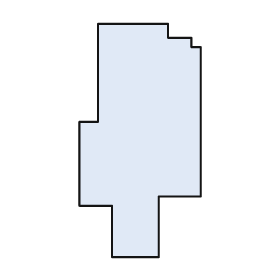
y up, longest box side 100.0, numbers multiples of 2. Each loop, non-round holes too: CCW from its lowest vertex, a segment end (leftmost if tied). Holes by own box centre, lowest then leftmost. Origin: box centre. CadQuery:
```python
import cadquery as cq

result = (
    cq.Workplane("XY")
    .moveTo(-12.0, -50.0)
    .lineTo(8.0, -50.0)
    .lineTo(8.0, -24.0)
    .lineTo(26.0, -24.0)
    .lineTo(26.0, 40.0)
    .lineTo(22.0, 40.0)
    .lineTo(22.0, 44.0)
    .lineTo(12.0, 44.0)
    .lineTo(12.0, 50.0)
    .lineTo(-18.0, 50.0)
    .lineTo(-18.0, 8.0)
    .lineTo(-26.0, 8.0)
    .lineTo(-26.0, -28.0)
    .lineTo(-12.0, -28.0)
    .close()
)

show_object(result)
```